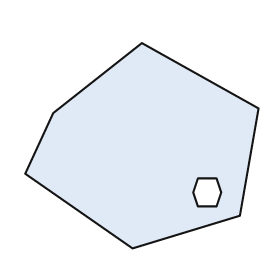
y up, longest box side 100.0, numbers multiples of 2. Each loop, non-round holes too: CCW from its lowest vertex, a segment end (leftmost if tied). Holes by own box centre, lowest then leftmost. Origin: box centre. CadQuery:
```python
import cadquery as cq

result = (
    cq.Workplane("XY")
    .moveTo(-4.0, -44.0)
    .lineTo(42.0, -30.0)
    .lineTo(50.0, 16.0)
    .lineTo(0.0, 44.0)
    .lineTo(-38.0, 14.0)
    .lineTo(-50.0, -12.0)
    .close()
    .moveTo(24.0, -26.0)
    .lineTo(32.0, -26.0)
    .lineTo(34.0, -20.0)
    .lineTo(32.0, -14.0)
    .lineTo(24.0, -14.0)
    .lineTo(22.0, -20.0)
    .close()
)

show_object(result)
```